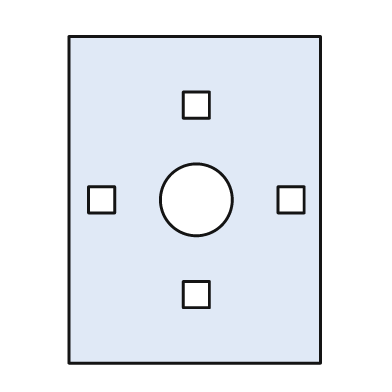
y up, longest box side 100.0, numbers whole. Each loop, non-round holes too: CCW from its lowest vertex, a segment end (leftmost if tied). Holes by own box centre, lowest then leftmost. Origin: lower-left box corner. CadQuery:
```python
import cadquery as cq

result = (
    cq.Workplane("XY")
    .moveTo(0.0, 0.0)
    .lineTo(77.0, 0.0)
    .lineTo(77.0, 100.0)
    .lineTo(0.0, 100.0)
    .close()
    .moveTo(35.0, 17.0)
    .lineTo(43.0, 17.0)
    .lineTo(43.0, 25.0)
    .lineTo(35.0, 25.0)
    .close()
    .moveTo(6.0, 46.0)
    .lineTo(14.0, 46.0)
    .lineTo(14.0, 54.0)
    .lineTo(6.0, 54.0)
    .close()
    .moveTo(39.0, 50.0)
    .circle(11.0)
    .moveTo(64.0, 46.0)
    .lineTo(72.0, 46.0)
    .lineTo(72.0, 54.0)
    .lineTo(64.0, 54.0)
    .close()
    .moveTo(35.0, 75.0)
    .lineTo(43.0, 75.0)
    .lineTo(43.0, 83.0)
    .lineTo(35.0, 83.0)
    .close()
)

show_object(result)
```